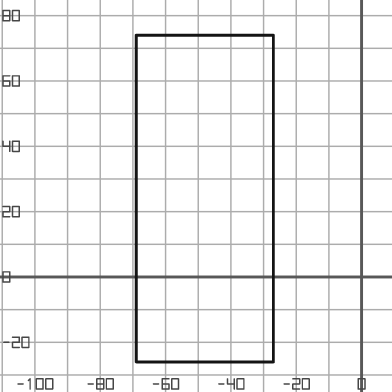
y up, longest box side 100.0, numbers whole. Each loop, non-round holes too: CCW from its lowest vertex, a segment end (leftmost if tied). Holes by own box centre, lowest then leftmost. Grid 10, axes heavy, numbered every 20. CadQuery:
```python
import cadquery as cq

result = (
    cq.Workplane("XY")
    .moveTo(-69.0, -26.0)
    .lineTo(-27.0, -26.0)
    .lineTo(-27.0, 74.0)
    .lineTo(-69.0, 74.0)
    .close()
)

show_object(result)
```